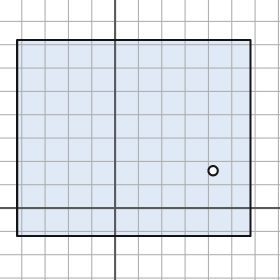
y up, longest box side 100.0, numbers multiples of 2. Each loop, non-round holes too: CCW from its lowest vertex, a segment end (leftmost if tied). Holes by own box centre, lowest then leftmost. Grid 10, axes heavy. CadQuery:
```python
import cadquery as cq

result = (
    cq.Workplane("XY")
    .moveTo(-42.0, -12.0)
    .lineTo(58.0, -12.0)
    .lineTo(58.0, 72.0)
    .lineTo(-42.0, 72.0)
    .close()
    .moveTo(42.0, 16.0)
    .circle(2.0)
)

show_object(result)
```